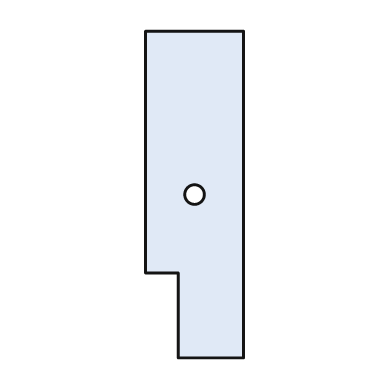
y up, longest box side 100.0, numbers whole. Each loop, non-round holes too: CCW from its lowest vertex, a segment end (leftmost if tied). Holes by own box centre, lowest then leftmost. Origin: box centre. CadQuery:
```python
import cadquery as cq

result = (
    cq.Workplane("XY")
    .moveTo(-5.0, -50.0)
    .lineTo(15.0, -50.0)
    .lineTo(15.0, 50.0)
    .lineTo(-15.0, 50.0)
    .lineTo(-15.0, -24.0)
    .lineTo(-5.0, -24.0)
    .close()
    .moveTo(0.0, 0.0)
    .circle(3.0)
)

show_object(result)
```